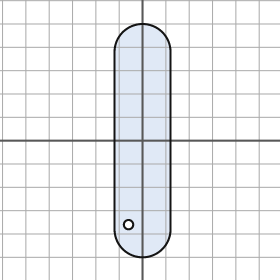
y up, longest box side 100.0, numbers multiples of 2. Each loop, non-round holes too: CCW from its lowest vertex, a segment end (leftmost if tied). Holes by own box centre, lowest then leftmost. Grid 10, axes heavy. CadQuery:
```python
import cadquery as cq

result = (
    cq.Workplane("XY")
    .moveTo(-12.0, -38.0)
    .threePointArc((0.0, -50.0), (12.0, -38.0))
    .lineTo(12.0, 38.0)
    .threePointArc((0.0, 50.0), (-12.0, 38.0))
    .close()
    .moveTo(-6.0, -36.0)
    .circle(2.0)
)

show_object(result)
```